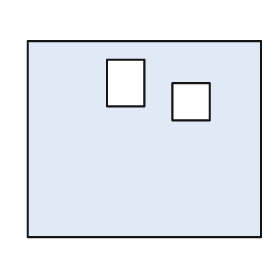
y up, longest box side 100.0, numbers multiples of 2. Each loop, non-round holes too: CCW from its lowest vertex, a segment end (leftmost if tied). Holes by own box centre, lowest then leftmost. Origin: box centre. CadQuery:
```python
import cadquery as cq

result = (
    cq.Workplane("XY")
    .moveTo(-50.0, -42.0)
    .lineTo(50.0, -42.0)
    .lineTo(50.0, 42.0)
    .lineTo(-50.0, 42.0)
    .close()
    .moveTo(12.0, 8.0)
    .lineTo(28.0, 8.0)
    .lineTo(28.0, 24.0)
    .lineTo(12.0, 24.0)
    .close()
    .moveTo(-16.0, 14.0)
    .lineTo(0.0, 14.0)
    .lineTo(0.0, 34.0)
    .lineTo(-16.0, 34.0)
    .close()
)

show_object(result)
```